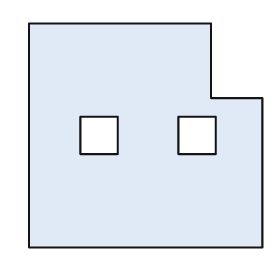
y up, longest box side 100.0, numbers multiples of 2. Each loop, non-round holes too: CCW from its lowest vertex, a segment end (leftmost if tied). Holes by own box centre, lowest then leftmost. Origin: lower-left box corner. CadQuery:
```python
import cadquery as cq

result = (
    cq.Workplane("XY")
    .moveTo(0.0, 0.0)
    .lineTo(100.0, 0.0)
    .lineTo(100.0, 64.0)
    .lineTo(78.0, 64.0)
    .lineTo(78.0, 96.0)
    .lineTo(0.0, 96.0)
    .close()
    .moveTo(22.0, 40.0)
    .lineTo(38.0, 40.0)
    .lineTo(38.0, 56.0)
    .lineTo(22.0, 56.0)
    .close()
    .moveTo(64.0, 40.0)
    .lineTo(80.0, 40.0)
    .lineTo(80.0, 56.0)
    .lineTo(64.0, 56.0)
    .close()
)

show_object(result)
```